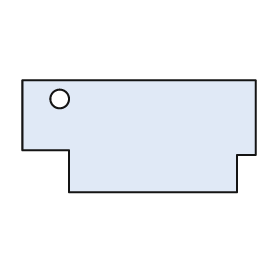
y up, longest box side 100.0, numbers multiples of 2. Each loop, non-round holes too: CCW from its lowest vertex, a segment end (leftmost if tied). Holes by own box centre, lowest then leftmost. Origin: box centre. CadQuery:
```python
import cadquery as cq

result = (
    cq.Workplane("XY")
    .moveTo(-30.0, -24.0)
    .lineTo(42.0, -24.0)
    .lineTo(42.0, -8.0)
    .lineTo(50.0, -8.0)
    .lineTo(50.0, 24.0)
    .lineTo(-50.0, 24.0)
    .lineTo(-50.0, -6.0)
    .lineTo(-30.0, -6.0)
    .close()
    .moveTo(-34.0, 16.0)
    .circle(4.0)
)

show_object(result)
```